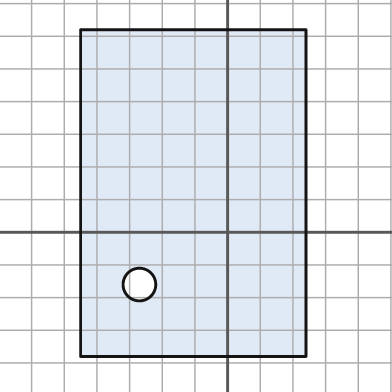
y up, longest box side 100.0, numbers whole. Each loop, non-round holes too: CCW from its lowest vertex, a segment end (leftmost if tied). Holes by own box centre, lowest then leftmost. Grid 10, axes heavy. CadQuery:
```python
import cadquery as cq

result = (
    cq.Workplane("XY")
    .moveTo(-45.0, -38.0)
    .lineTo(24.0, -38.0)
    .lineTo(24.0, 62.0)
    .lineTo(-45.0, 62.0)
    .close()
    .moveTo(-27.0, -16.0)
    .circle(5.0)
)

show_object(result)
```